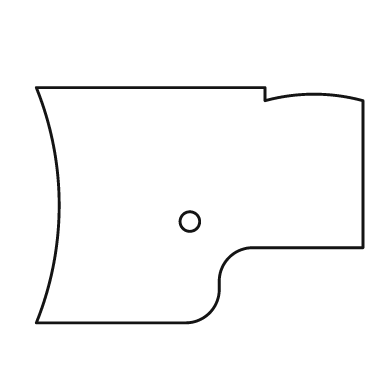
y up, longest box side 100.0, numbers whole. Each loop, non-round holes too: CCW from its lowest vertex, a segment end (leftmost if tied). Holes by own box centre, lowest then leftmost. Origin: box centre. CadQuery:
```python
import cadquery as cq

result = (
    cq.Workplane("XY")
    .moveTo(-50.0, -36.0)
    .lineTo(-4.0, -36.0)
    .threePointArc((3.0, -33.0), (6.0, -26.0))
    .lineTo(6.0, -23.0)
    .threePointArc((9.0, -16.0), (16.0, -13.0))
    .lineTo(50.0, -13.0)
    .lineTo(50.0, 32.0)
    .threePointArc((35.0, 34.0), (20.0, 32.0))
    .lineTo(20.0, 36.0)
    .lineTo(-50.0, 36.0)
    .threePointArc((-43.0, 0.0), (-50.0, -36.0))
    .close()
    .moveTo(-3.0, -5.0)
    .circle(3.0)
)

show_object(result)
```